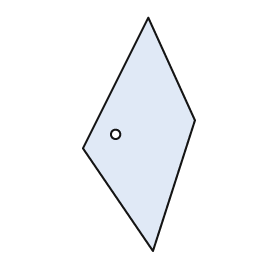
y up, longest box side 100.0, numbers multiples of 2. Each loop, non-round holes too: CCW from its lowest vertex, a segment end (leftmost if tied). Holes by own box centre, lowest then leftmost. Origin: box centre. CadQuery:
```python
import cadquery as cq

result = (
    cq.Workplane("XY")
    .moveTo(6.0, -50.0)
    .lineTo(24.0, 6.0)
    .lineTo(4.0, 50.0)
    .lineTo(-24.0, -6.0)
    .close()
    .moveTo(-10.0, 0.0)
    .circle(2.0)
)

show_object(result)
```